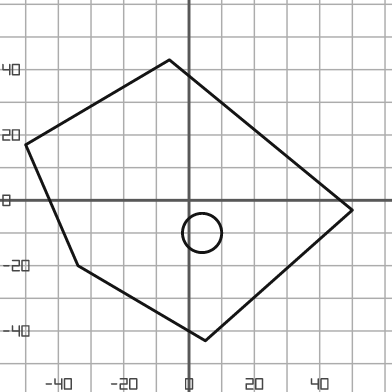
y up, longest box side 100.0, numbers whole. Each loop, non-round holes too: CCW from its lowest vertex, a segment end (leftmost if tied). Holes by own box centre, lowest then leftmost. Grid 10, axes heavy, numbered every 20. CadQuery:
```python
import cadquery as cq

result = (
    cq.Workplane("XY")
    .moveTo(5.0, -43.0)
    .lineTo(50.0, -3.0)
    .lineTo(-6.0, 43.0)
    .lineTo(-50.0, 17.0)
    .lineTo(-34.0, -20.0)
    .close()
    .moveTo(4.0, -10.0)
    .circle(6.0)
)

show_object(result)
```